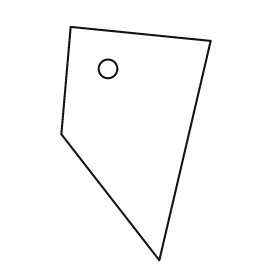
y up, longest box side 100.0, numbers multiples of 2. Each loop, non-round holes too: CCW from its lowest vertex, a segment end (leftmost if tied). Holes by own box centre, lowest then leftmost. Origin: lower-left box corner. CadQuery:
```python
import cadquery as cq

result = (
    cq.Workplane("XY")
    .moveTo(42.0, 0.0)
    .lineTo(64.0, 94.0)
    .lineTo(4.0, 100.0)
    .lineTo(0.0, 54.0)
    .close()
    .moveTo(20.0, 82.0)
    .circle(4.0)
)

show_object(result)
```